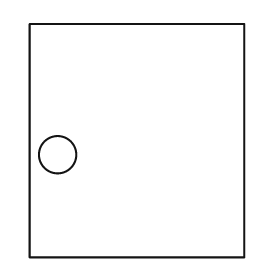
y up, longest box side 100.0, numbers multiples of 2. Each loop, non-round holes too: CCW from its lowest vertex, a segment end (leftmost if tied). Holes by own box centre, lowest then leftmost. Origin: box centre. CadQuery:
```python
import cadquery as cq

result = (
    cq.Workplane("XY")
    .moveTo(-46.0, -50.0)
    .lineTo(46.0, -50.0)
    .lineTo(46.0, 50.0)
    .lineTo(-46.0, 50.0)
    .close()
    .moveTo(-34.0, -6.0)
    .circle(8.0)
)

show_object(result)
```